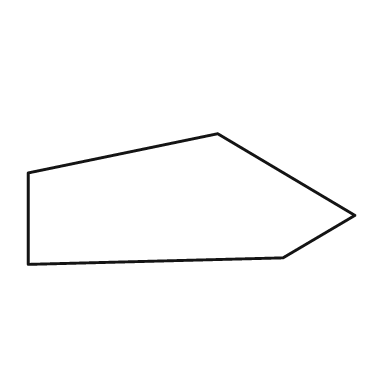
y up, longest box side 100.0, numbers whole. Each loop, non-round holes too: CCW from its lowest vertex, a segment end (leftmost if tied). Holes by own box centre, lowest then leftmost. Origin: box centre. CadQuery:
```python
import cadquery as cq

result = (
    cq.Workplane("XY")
    .moveTo(-50.0, -20.0)
    .lineTo(28.0, -18.0)
    .lineTo(50.0, -5.0)
    .lineTo(8.0, 20.0)
    .lineTo(-50.0, 8.0)
    .close()
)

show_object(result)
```